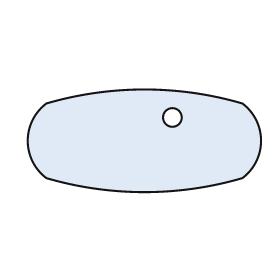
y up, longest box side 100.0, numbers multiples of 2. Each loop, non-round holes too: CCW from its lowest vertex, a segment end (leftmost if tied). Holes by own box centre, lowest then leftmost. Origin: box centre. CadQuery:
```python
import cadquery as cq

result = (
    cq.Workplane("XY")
    .moveTo(-42.0, -16.0)
    .threePointArc((0.0, -22.0), (42.0, -16.0))
    .threePointArc((50.0, 0.0), (42.0, 16.0))
    .threePointArc((0.0, 22.0), (-42.0, 16.0))
    .threePointArc((-50.0, 0.0), (-42.0, -16.0))
    .close()
    .moveTo(12.0, 10.0)
    .circle(4.0)
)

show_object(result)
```